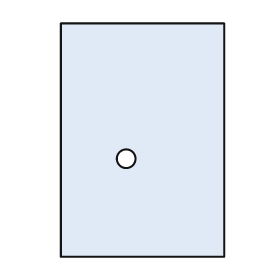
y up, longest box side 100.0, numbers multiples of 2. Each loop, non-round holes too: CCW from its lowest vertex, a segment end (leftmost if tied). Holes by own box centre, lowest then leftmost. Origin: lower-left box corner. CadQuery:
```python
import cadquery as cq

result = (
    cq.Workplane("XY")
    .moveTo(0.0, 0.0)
    .lineTo(70.0, 0.0)
    .lineTo(70.0, 100.0)
    .lineTo(0.0, 100.0)
    .close()
    .moveTo(28.0, 42.0)
    .circle(4.0)
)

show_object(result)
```